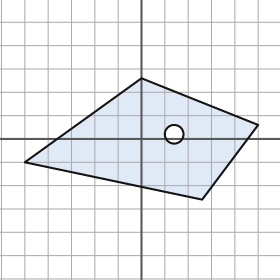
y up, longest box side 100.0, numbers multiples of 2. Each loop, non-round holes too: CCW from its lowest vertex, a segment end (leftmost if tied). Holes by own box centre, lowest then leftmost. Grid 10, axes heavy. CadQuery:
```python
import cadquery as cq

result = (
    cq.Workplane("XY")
    .moveTo(26.0, -26.0)
    .lineTo(50.0, 6.0)
    .lineTo(0.0, 26.0)
    .lineTo(-50.0, -10.0)
    .close()
    .moveTo(14.0, 2.0)
    .circle(4.0)
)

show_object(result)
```